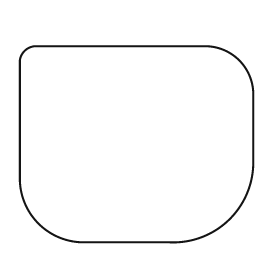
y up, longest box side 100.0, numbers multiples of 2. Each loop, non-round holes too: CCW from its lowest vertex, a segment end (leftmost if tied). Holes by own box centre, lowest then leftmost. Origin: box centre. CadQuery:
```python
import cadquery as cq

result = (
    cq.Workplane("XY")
    .moveTo(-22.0, -42.0)
    .lineTo(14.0, -42.0)
    .threePointArc((40.0, -32.0), (50.0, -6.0))
    .lineTo(50.0, 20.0)
    .threePointArc((44.0, 36.0), (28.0, 42.0))
    .lineTo(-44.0, 42.0)
    .threePointArc((-48.0, 40.0), (-50.0, 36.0))
    .lineTo(-50.0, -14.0)
    .threePointArc((-42.0, -34.0), (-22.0, -42.0))
    .close()
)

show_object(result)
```